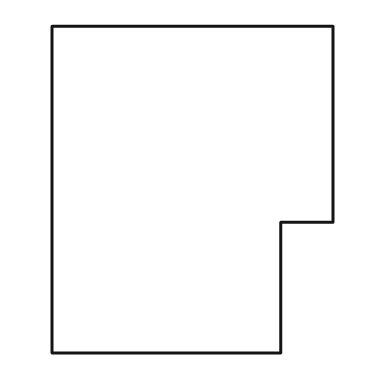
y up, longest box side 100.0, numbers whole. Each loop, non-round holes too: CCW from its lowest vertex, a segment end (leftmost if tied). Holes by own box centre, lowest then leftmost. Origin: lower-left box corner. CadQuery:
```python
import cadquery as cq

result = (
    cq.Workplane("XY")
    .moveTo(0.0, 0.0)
    .lineTo(70.0, 0.0)
    .lineTo(70.0, 40.0)
    .lineTo(86.0, 40.0)
    .lineTo(86.0, 100.0)
    .lineTo(0.0, 100.0)
    .close()
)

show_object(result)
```